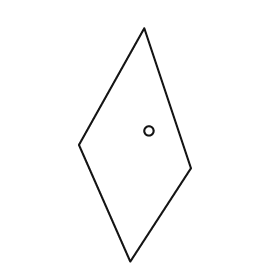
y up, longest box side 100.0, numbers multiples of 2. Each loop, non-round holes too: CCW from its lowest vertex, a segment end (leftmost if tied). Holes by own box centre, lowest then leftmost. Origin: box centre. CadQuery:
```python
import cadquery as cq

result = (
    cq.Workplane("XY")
    .moveTo(-2.0, -50.0)
    .lineTo(24.0, -10.0)
    .lineTo(4.0, 50.0)
    .lineTo(-24.0, 0.0)
    .close()
    .moveTo(6.0, 6.0)
    .circle(2.0)
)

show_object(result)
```